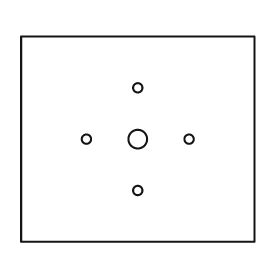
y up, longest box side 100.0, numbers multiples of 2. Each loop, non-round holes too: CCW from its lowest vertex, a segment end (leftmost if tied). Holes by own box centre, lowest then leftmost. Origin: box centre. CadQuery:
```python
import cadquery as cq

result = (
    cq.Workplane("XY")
    .moveTo(-50.0, -44.0)
    .lineTo(50.0, -44.0)
    .lineTo(50.0, 44.0)
    .lineTo(-50.0, 44.0)
    .close()
    .moveTo(0.0, -22.0)
    .circle(2.0)
    .moveTo(-22.0, 0.0)
    .circle(2.0)
    .moveTo(0.0, 0.0)
    .circle(4.0)
    .moveTo(22.0, 0.0)
    .circle(2.0)
    .moveTo(0.0, 22.0)
    .circle(2.0)
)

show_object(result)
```